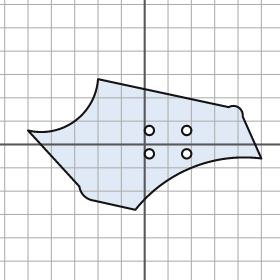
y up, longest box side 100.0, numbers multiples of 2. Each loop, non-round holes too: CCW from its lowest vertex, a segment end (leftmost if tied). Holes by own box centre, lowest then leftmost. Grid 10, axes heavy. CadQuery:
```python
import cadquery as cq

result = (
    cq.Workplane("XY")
    .moveTo(-4.0, -28.0)
    .threePointArc((20.0, -10.0), (50.0, -6.0))
    .lineTo(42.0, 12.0)
    .threePointArc((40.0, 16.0), (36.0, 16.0))
    .lineTo(-20.0, 28.0)
    .threePointArc((-30.0, 10.0), (-50.0, 6.0))
    .lineTo(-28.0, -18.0)
    .threePointArc((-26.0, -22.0), (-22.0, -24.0))
    .close()
    .moveTo(2.0, -4.0)
    .circle(2.0)
    .moveTo(18.0, -4.0)
    .circle(2.0)
    .moveTo(2.0, 6.0)
    .circle(2.0)
    .moveTo(18.0, 6.0)
    .circle(2.0)
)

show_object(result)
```